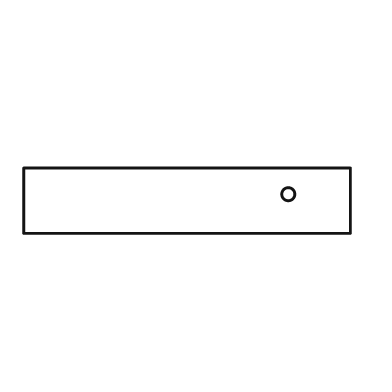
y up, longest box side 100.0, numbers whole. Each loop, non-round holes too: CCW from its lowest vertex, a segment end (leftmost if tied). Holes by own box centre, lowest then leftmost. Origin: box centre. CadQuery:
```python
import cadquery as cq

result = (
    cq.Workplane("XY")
    .moveTo(-50.0, -10.0)
    .lineTo(50.0, -10.0)
    .lineTo(50.0, 10.0)
    .lineTo(-50.0, 10.0)
    .close()
    .moveTo(31.0, 2.0)
    .circle(2.0)
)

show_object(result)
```